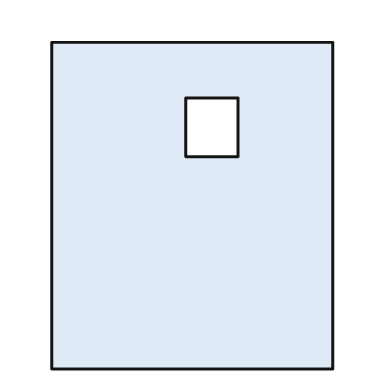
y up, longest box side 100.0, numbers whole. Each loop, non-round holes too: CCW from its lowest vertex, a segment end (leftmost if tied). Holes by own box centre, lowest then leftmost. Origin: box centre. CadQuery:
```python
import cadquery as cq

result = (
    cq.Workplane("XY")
    .moveTo(-43.0, -50.0)
    .lineTo(43.0, -50.0)
    .lineTo(43.0, 50.0)
    .lineTo(-43.0, 50.0)
    .close()
    .moveTo(-2.0, 15.0)
    .lineTo(14.0, 15.0)
    .lineTo(14.0, 33.0)
    .lineTo(-2.0, 33.0)
    .close()
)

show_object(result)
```